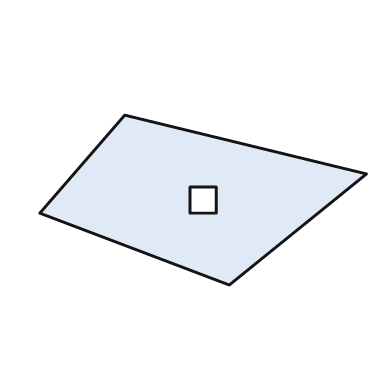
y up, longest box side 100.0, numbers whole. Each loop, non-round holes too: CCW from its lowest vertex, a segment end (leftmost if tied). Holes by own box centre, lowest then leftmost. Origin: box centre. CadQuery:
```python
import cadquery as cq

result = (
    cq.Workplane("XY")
    .moveTo(8.0, -26.0)
    .lineTo(50.0, 8.0)
    .lineTo(-24.0, 26.0)
    .lineTo(-50.0, -4.0)
    .close()
    .moveTo(-4.0, -4.0)
    .lineTo(4.0, -4.0)
    .lineTo(4.0, 4.0)
    .lineTo(-4.0, 4.0)
    .close()
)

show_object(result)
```